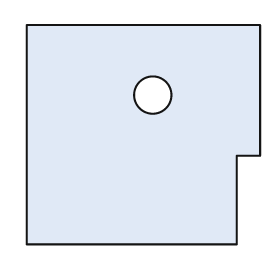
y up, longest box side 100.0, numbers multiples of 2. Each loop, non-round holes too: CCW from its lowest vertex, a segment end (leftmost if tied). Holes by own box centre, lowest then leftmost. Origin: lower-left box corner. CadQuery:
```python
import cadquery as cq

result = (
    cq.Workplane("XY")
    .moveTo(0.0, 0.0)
    .lineTo(90.0, 0.0)
    .lineTo(90.0, 38.0)
    .lineTo(100.0, 38.0)
    .lineTo(100.0, 94.0)
    .lineTo(0.0, 94.0)
    .close()
    .moveTo(54.0, 64.0)
    .circle(8.0)
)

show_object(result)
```